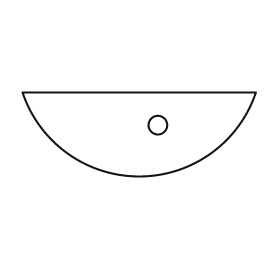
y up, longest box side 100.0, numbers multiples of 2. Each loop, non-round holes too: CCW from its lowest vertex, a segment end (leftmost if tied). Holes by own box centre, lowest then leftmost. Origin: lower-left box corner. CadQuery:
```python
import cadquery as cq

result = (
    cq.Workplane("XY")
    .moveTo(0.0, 36.0)
    .threePointArc((50.0, 0.0), (100.0, 36.0))
    .close()
    .moveTo(58.0, 22.0)
    .circle(4.0)
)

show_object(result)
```